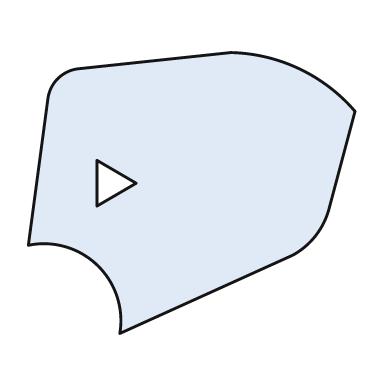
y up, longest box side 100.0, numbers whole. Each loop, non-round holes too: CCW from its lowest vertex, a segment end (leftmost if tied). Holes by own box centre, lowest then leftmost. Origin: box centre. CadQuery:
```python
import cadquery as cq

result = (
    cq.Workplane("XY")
    .moveTo(-22.0, -43.0)
    .lineTo(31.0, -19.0)
    .threePointArc((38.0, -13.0), (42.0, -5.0))
    .lineTo(50.0, 25.0)
    .threePointArc((33.0, 38.0), (12.0, 43.0))
    .lineTo(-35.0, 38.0)
    .threePointArc((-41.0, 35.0), (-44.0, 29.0))
    .lineTo(-50.0, -16.0)
    .threePointArc((-29.0, -22.0), (-22.0, -43.0))
    .close()
    .moveTo(-29.0, -4.0)
    .lineTo(-17.0, 3.0)
    .lineTo(-29.0, 10.0)
    .close()
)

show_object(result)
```